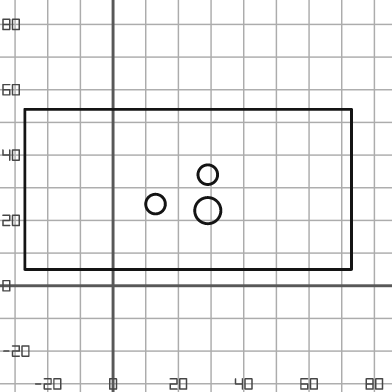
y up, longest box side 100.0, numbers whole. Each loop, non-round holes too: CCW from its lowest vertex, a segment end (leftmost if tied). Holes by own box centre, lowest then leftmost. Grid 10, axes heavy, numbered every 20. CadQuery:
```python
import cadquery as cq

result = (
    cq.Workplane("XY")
    .moveTo(-27.0, 5.0)
    .lineTo(73.0, 5.0)
    .lineTo(73.0, 54.0)
    .lineTo(-27.0, 54.0)
    .close()
    .moveTo(29.0, 23.0)
    .circle(4.0)
    .moveTo(13.0, 25.0)
    .circle(3.0)
    .moveTo(29.0, 34.0)
    .circle(3.0)
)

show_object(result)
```